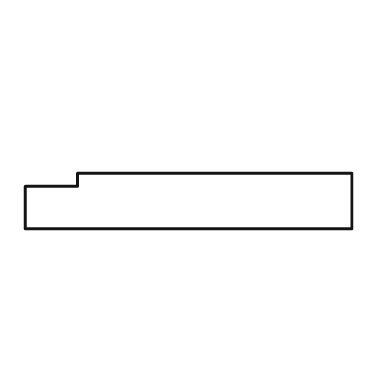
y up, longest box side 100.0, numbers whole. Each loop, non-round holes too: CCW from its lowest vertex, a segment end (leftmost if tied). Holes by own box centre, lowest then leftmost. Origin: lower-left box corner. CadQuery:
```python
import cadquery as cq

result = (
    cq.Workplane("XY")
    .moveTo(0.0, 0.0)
    .lineTo(100.0, 0.0)
    .lineTo(100.0, 17.0)
    .lineTo(16.0, 17.0)
    .lineTo(16.0, 13.0)
    .lineTo(0.0, 13.0)
    .close()
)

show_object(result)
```